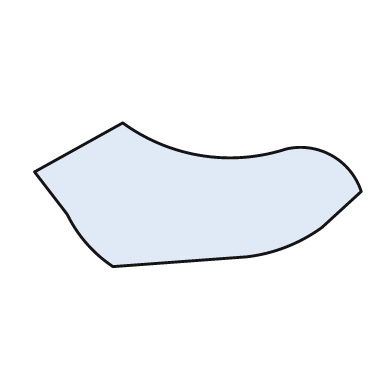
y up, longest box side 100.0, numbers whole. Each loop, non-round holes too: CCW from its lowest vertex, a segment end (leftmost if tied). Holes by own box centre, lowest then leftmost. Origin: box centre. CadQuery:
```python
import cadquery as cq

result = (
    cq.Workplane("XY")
    .moveTo(-26.0, -22.0)
    .lineTo(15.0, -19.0)
    .threePointArc((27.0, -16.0), (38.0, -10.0))
    .lineTo(50.0, 1.0)
    .threePointArc((41.0, 12.0), (27.0, 14.0))
    .threePointArc((1.0, 12.0), (-23.0, 22.0))
    .lineTo(-50.0, 7.0)
    .lineTo(-40.0, -6.0)
    .threePointArc((-34.0, -15.0), (-26.0, -22.0))
    .close()
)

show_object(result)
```